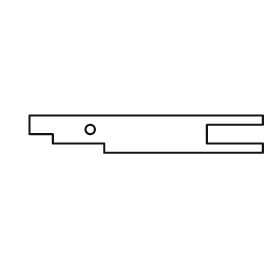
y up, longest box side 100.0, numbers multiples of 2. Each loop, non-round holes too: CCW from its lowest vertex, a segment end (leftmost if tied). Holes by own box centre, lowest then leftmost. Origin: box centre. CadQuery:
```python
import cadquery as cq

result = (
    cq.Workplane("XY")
    .moveTo(-18.0, -8.0)
    .lineTo(50.0, -8.0)
    .lineTo(50.0, -4.0)
    .lineTo(26.0, -4.0)
    .lineTo(26.0, 4.0)
    .lineTo(50.0, 4.0)
    .lineTo(50.0, 8.0)
    .lineTo(-50.0, 8.0)
    .lineTo(-50.0, 0.0)
    .lineTo(-40.0, 0.0)
    .lineTo(-40.0, -4.0)
    .lineTo(-18.0, -4.0)
    .close()
    .moveTo(-24.0, 2.0)
    .circle(2.0)
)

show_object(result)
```